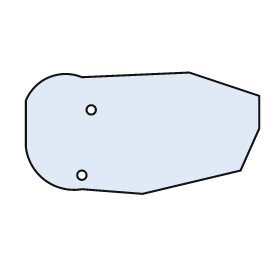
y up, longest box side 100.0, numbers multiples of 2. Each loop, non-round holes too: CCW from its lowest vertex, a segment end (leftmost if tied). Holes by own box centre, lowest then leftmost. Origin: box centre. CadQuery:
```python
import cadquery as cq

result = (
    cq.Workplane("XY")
    .moveTo(0.0, -26.0)
    .lineTo(42.0, -16.0)
    .lineTo(50.0, 2.0)
    .lineTo(50.0, 16.0)
    .lineTo(20.0, 26.0)
    .lineTo(-26.0, 24.0)
    .threePointArc((-40.0, 24.0), (-50.0, 14.0))
    .lineTo(-50.0, -6.0)
    .threePointArc((-42.0, -20.0), (-26.0, -24.0))
    .close()
    .moveTo(-26.0, -18.0)
    .circle(2.0)
    .moveTo(-22.0, 10.0)
    .circle(2.0)
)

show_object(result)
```